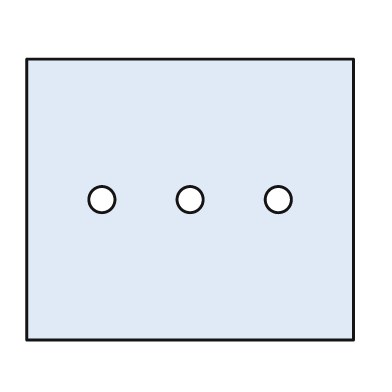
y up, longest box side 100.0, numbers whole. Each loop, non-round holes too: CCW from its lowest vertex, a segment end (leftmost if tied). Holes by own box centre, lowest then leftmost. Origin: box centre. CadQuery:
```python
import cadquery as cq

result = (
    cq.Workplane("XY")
    .moveTo(-50.0, -43.0)
    .lineTo(50.0, -43.0)
    .lineTo(50.0, 43.0)
    .lineTo(-50.0, 43.0)
    .close()
    .moveTo(-27.0, 0.0)
    .circle(4.0)
    .moveTo(0.0, 0.0)
    .circle(4.0)
    .moveTo(27.0, 0.0)
    .circle(4.0)
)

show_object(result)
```